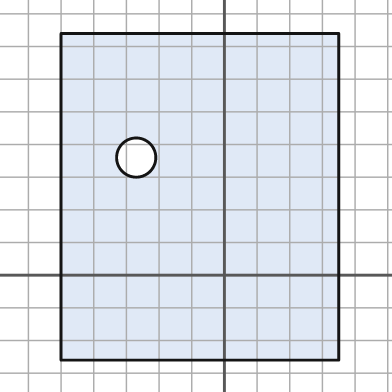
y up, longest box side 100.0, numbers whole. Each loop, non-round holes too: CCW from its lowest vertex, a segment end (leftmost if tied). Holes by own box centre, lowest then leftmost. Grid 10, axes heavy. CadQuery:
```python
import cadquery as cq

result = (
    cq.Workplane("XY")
    .moveTo(-50.0, -26.0)
    .lineTo(35.0, -26.0)
    .lineTo(35.0, 74.0)
    .lineTo(-50.0, 74.0)
    .close()
    .moveTo(-27.0, 36.0)
    .circle(6.0)
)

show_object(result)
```